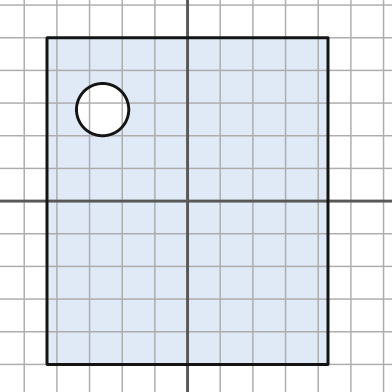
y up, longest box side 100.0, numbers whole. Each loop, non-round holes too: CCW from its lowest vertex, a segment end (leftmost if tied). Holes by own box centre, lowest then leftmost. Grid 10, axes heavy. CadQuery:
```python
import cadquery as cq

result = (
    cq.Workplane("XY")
    .moveTo(-43.0, -50.0)
    .lineTo(43.0, -50.0)
    .lineTo(43.0, 50.0)
    .lineTo(-43.0, 50.0)
    .close()
    .moveTo(-26.0, 28.0)
    .circle(8.0)
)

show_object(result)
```